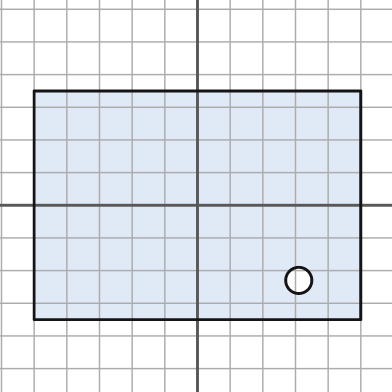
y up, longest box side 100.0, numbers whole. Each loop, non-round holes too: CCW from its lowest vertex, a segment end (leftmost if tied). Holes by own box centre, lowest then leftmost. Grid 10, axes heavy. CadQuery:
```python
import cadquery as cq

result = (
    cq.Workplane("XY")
    .moveTo(-50.0, -35.0)
    .lineTo(50.0, -35.0)
    .lineTo(50.0, 35.0)
    .lineTo(-50.0, 35.0)
    .close()
    .moveTo(31.0, -23.0)
    .circle(4.0)
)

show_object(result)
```